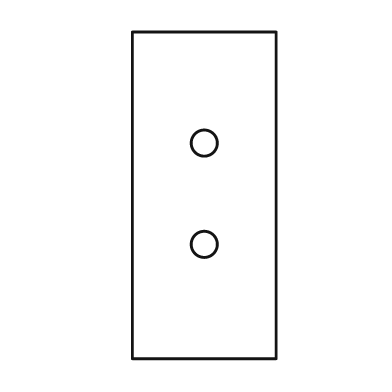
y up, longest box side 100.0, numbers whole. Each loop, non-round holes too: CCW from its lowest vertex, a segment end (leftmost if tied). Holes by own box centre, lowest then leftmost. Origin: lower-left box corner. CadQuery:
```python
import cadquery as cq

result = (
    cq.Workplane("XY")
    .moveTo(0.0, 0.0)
    .lineTo(44.0, 0.0)
    .lineTo(44.0, 100.0)
    .lineTo(0.0, 100.0)
    .close()
    .moveTo(22.0, 35.0)
    .circle(4.0)
    .moveTo(22.0, 66.0)
    .circle(4.0)
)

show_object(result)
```